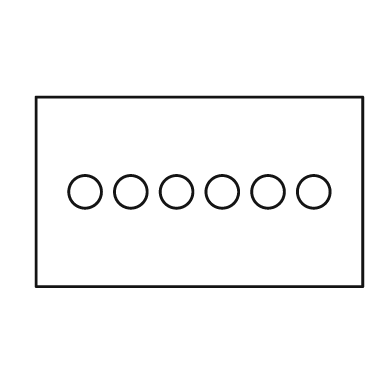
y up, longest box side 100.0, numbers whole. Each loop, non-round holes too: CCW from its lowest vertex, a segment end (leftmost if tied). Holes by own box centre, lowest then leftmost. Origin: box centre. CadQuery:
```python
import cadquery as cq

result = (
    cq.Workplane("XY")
    .moveTo(-50.0, -29.0)
    .lineTo(50.0, -29.0)
    .lineTo(50.0, 29.0)
    .lineTo(-50.0, 29.0)
    .close()
    .moveTo(-35.0, 0.0)
    .circle(5.0)
    .moveTo(-21.0, 0.0)
    .circle(5.0)
    .moveTo(-7.0, 0.0)
    .circle(5.0)
    .moveTo(7.0, 0.0)
    .circle(5.0)
    .moveTo(21.0, 0.0)
    .circle(5.0)
    .moveTo(35.0, 0.0)
    .circle(5.0)
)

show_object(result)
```